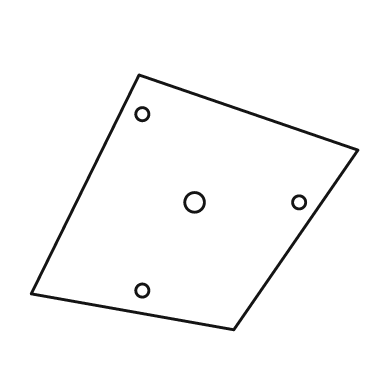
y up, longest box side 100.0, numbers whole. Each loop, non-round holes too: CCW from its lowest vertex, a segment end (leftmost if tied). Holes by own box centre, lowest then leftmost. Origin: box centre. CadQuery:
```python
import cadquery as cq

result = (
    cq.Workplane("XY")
    .moveTo(12.0, -39.0)
    .lineTo(50.0, 16.0)
    .lineTo(-17.0, 39.0)
    .lineTo(-50.0, -28.0)
    .close()
    .moveTo(-16.0, -27.0)
    .circle(2.0)
    .moveTo(0.0, 0.0)
    .circle(3.0)
    .moveTo(32.0, 0.0)
    .circle(2.0)
    .moveTo(-16.0, 27.0)
    .circle(2.0)
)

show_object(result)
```